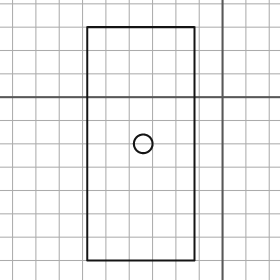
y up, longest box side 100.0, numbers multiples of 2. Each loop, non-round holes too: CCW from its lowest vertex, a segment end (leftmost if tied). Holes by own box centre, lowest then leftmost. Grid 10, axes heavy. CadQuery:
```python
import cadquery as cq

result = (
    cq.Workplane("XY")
    .moveTo(-58.0, -70.0)
    .lineTo(-12.0, -70.0)
    .lineTo(-12.0, 30.0)
    .lineTo(-58.0, 30.0)
    .close()
    .moveTo(-34.0, -20.0)
    .circle(4.0)
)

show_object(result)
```